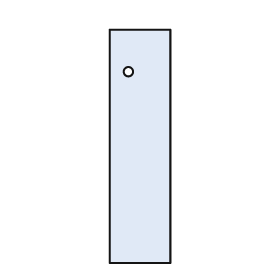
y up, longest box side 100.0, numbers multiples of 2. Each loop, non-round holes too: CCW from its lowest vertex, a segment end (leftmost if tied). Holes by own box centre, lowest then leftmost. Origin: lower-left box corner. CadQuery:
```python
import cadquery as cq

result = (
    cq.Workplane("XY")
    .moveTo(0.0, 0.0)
    .lineTo(26.0, 0.0)
    .lineTo(26.0, 100.0)
    .lineTo(0.0, 100.0)
    .close()
    .moveTo(8.0, 82.0)
    .circle(2.0)
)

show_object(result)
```